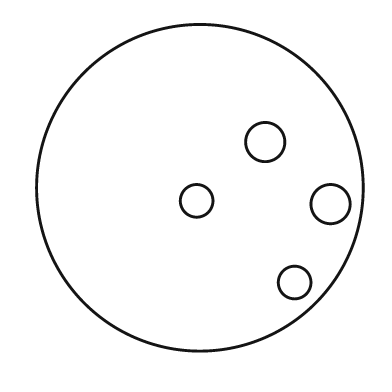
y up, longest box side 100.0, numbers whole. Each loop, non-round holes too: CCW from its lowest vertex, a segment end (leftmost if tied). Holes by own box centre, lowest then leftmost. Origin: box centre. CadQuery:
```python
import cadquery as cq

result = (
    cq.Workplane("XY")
    .moveTo(0.0, 0.0)
    .circle(50.0)
    .moveTo(29.0, -29.0)
    .circle(5.0)
    .moveTo(40.0, -5.0)
    .circle(6.0)
    .moveTo(-1.0, -4.0)
    .circle(5.0)
    .moveTo(20.0, 14.0)
    .circle(6.0)
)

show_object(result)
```